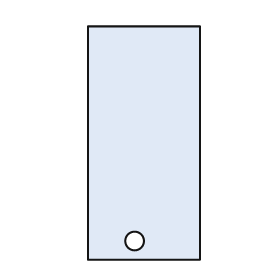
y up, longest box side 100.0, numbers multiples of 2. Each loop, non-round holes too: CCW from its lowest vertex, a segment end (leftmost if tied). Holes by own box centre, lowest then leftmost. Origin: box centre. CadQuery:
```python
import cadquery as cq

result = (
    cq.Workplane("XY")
    .moveTo(-24.0, -50.0)
    .lineTo(24.0, -50.0)
    .lineTo(24.0, 50.0)
    .lineTo(-24.0, 50.0)
    .close()
    .moveTo(-4.0, -42.0)
    .circle(4.0)
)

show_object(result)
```